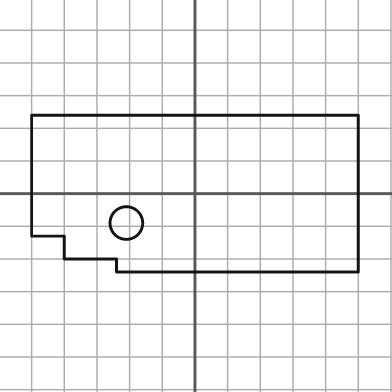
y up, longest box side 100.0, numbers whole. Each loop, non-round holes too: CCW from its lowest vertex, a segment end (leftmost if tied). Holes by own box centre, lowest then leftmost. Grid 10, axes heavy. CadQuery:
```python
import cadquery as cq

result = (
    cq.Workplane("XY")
    .moveTo(-24.0, -24.0)
    .lineTo(50.0, -24.0)
    .lineTo(50.0, 24.0)
    .lineTo(-50.0, 24.0)
    .lineTo(-50.0, -13.0)
    .lineTo(-40.0, -13.0)
    .lineTo(-40.0, -20.0)
    .lineTo(-24.0, -20.0)
    .close()
    .moveTo(-21.0, -9.0)
    .circle(5.0)
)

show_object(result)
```